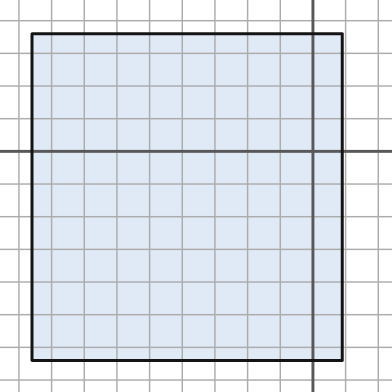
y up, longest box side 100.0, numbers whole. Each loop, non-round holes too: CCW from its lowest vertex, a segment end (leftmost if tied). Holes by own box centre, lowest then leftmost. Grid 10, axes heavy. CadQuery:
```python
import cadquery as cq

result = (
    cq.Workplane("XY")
    .moveTo(-86.0, -64.0)
    .lineTo(9.0, -64.0)
    .lineTo(9.0, 36.0)
    .lineTo(-86.0, 36.0)
    .close()
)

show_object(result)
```